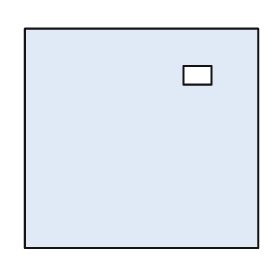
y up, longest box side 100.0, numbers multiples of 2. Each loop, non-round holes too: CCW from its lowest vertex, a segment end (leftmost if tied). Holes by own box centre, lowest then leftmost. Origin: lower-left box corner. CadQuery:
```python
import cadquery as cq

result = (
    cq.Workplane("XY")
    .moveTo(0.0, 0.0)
    .lineTo(100.0, 0.0)
    .lineTo(100.0, 94.0)
    .lineTo(0.0, 94.0)
    .close()
    .moveTo(68.0, 70.0)
    .lineTo(80.0, 70.0)
    .lineTo(80.0, 78.0)
    .lineTo(68.0, 78.0)
    .close()
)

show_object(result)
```